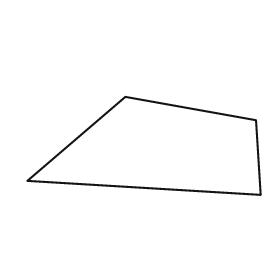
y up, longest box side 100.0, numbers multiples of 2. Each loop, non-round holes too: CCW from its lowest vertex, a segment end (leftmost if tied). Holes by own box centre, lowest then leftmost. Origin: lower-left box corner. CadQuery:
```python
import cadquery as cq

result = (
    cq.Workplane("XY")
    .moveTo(100.0, 0.0)
    .lineTo(98.0, 32.0)
    .lineTo(42.0, 42.0)
    .lineTo(0.0, 6.0)
    .close()
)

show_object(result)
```